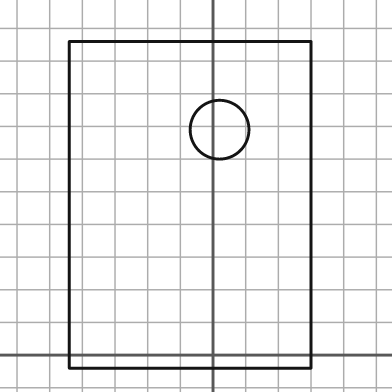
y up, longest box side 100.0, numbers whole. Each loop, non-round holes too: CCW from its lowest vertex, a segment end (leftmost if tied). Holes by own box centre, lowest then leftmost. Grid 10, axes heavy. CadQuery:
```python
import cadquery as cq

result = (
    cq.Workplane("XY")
    .moveTo(-44.0, -4.0)
    .lineTo(30.0, -4.0)
    .lineTo(30.0, 96.0)
    .lineTo(-44.0, 96.0)
    .close()
    .moveTo(2.0, 69.0)
    .circle(9.0)
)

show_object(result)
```